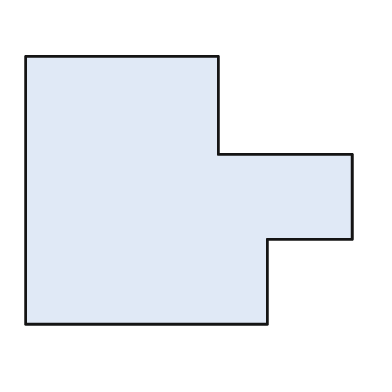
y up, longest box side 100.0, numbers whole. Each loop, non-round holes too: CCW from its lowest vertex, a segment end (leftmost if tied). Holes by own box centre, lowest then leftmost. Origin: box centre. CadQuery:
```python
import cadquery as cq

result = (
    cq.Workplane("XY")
    .moveTo(-50.0, -41.0)
    .lineTo(24.0, -41.0)
    .lineTo(24.0, -15.0)
    .lineTo(50.0, -15.0)
    .lineTo(50.0, 11.0)
    .lineTo(9.0, 11.0)
    .lineTo(9.0, 41.0)
    .lineTo(-50.0, 41.0)
    .close()
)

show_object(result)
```